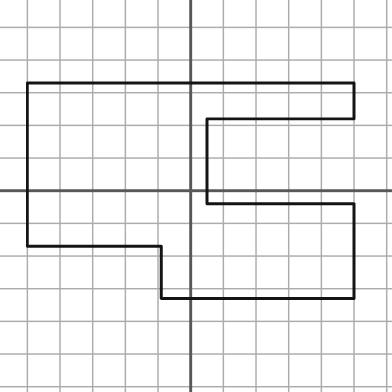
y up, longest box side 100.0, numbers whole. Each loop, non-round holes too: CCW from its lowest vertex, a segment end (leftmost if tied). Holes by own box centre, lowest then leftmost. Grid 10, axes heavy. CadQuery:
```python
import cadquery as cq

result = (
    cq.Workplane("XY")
    .moveTo(-9.0, -33.0)
    .lineTo(50.0, -33.0)
    .lineTo(50.0, -4.0)
    .lineTo(5.0, -4.0)
    .lineTo(5.0, 22.0)
    .lineTo(50.0, 22.0)
    .lineTo(50.0, 33.0)
    .lineTo(-50.0, 33.0)
    .lineTo(-50.0, -17.0)
    .lineTo(-9.0, -17.0)
    .close()
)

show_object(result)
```